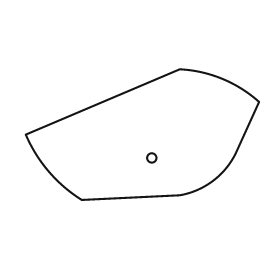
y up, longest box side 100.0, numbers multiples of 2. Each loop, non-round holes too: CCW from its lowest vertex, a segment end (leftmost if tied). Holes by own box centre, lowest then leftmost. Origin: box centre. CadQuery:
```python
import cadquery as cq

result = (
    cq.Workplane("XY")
    .moveTo(-26.0, -28.0)
    .lineTo(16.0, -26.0)
    .threePointArc((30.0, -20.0), (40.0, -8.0))
    .lineTo(50.0, 14.0)
    .threePointArc((34.0, 24.0), (16.0, 28.0))
    .lineTo(-50.0, 0.0)
    .threePointArc((-40.0, -16.0), (-26.0, -28.0))
    .close()
    .moveTo(4.0, -10.0)
    .circle(2.0)
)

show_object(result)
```